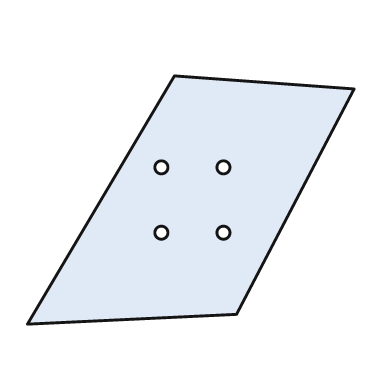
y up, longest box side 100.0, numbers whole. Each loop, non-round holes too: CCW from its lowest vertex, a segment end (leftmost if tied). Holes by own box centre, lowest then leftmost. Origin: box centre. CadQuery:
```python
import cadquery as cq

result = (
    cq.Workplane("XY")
    .moveTo(-50.0, -38.0)
    .lineTo(14.0, -35.0)
    .lineTo(50.0, 34.0)
    .lineTo(-5.0, 38.0)
    .close()
    .moveTo(-9.0, -10.0)
    .circle(2.0)
    .moveTo(10.0, -10.0)
    .circle(2.0)
    .moveTo(-9.0, 10.0)
    .circle(2.0)
    .moveTo(10.0, 10.0)
    .circle(2.0)
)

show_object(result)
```